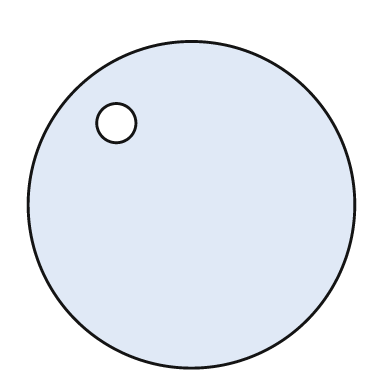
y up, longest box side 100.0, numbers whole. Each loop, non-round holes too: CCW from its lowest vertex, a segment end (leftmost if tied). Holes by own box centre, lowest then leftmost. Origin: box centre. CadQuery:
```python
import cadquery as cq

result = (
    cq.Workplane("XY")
    .moveTo(0.0, 0.0)
    .circle(50.0)
    .moveTo(-23.0, 25.0)
    .circle(6.0)
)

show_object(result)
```